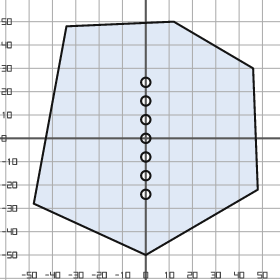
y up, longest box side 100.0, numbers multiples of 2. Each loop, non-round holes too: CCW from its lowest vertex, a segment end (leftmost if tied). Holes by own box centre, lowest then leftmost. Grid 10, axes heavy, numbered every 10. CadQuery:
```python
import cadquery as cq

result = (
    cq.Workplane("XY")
    .moveTo(0.0, -50.0)
    .lineTo(48.0, -22.0)
    .lineTo(46.0, 30.0)
    .lineTo(12.0, 50.0)
    .lineTo(-34.0, 48.0)
    .lineTo(-48.0, -28.0)
    .close()
    .moveTo(0.0, -24.0)
    .circle(2.0)
    .moveTo(0.0, -16.0)
    .circle(2.0)
    .moveTo(0.0, -8.0)
    .circle(2.0)
    .moveTo(0.0, 0.0)
    .circle(2.0)
    .moveTo(0.0, 8.0)
    .circle(2.0)
    .moveTo(0.0, 16.0)
    .circle(2.0)
    .moveTo(0.0, 24.0)
    .circle(2.0)
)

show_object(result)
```